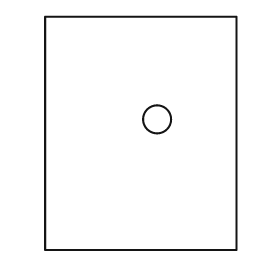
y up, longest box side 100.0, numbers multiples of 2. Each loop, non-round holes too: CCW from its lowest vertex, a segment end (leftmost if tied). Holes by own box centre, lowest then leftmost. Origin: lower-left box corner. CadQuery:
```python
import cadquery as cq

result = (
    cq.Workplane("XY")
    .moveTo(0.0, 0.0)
    .lineTo(82.0, 0.0)
    .lineTo(82.0, 100.0)
    .lineTo(0.0, 100.0)
    .close()
    .moveTo(48.0, 56.0)
    .circle(6.0)
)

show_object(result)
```